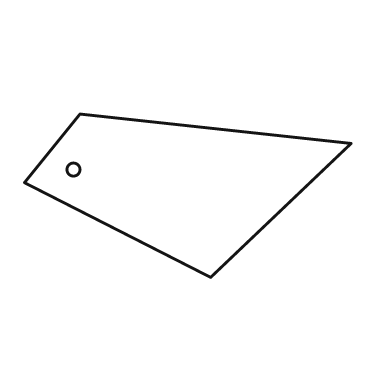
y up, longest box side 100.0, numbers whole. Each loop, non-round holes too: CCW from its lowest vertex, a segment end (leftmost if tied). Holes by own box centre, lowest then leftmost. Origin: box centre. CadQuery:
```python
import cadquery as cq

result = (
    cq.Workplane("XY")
    .moveTo(7.0, -25.0)
    .lineTo(50.0, 16.0)
    .lineTo(-33.0, 25.0)
    .lineTo(-50.0, 4.0)
    .close()
    .moveTo(-35.0, 8.0)
    .circle(2.0)
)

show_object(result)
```